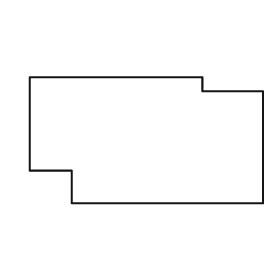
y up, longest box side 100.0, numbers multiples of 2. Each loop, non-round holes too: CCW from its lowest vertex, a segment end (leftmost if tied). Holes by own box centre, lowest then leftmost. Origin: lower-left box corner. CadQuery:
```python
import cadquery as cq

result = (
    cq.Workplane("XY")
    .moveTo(18.0, 0.0)
    .lineTo(100.0, 0.0)
    .lineTo(100.0, 48.0)
    .lineTo(74.0, 48.0)
    .lineTo(74.0, 54.0)
    .lineTo(0.0, 54.0)
    .lineTo(0.0, 14.0)
    .lineTo(18.0, 14.0)
    .close()
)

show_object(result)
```